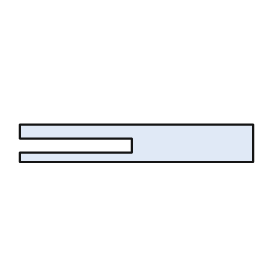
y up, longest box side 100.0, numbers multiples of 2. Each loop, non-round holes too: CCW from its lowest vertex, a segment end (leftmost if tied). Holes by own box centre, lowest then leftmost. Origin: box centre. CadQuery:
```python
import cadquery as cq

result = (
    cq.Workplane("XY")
    .moveTo(-50.0, -8.0)
    .lineTo(50.0, -8.0)
    .lineTo(50.0, 8.0)
    .lineTo(-50.0, 8.0)
    .lineTo(-50.0, 2.0)
    .lineTo(-2.0, 2.0)
    .lineTo(-2.0, -4.0)
    .lineTo(-50.0, -4.0)
    .close()
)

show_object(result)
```